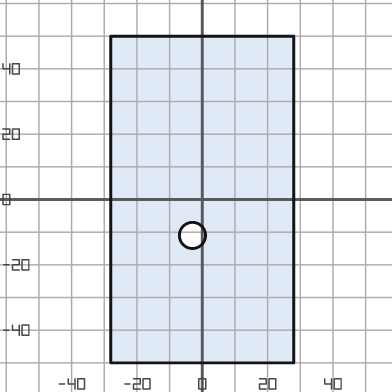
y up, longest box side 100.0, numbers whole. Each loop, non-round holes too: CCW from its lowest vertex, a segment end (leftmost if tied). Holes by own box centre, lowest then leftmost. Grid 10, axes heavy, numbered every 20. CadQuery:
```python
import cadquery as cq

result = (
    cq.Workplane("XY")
    .moveTo(-28.0, -50.0)
    .lineTo(28.0, -50.0)
    .lineTo(28.0, 50.0)
    .lineTo(-28.0, 50.0)
    .close()
    .moveTo(-3.0, -11.0)
    .circle(4.0)
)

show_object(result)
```